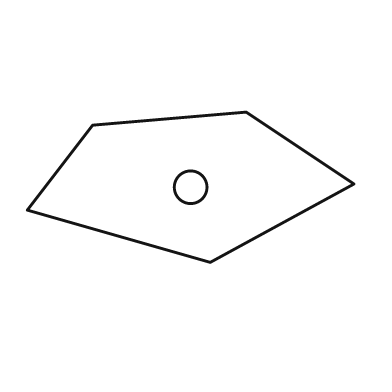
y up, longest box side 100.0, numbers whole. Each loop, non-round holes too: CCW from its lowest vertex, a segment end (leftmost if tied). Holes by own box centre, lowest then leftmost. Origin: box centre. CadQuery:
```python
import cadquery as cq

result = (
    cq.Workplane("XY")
    .moveTo(6.0, -23.0)
    .lineTo(50.0, 1.0)
    .lineTo(17.0, 23.0)
    .lineTo(-30.0, 19.0)
    .lineTo(-50.0, -7.0)
    .close()
    .moveTo(0.0, 0.0)
    .circle(5.0)
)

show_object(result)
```